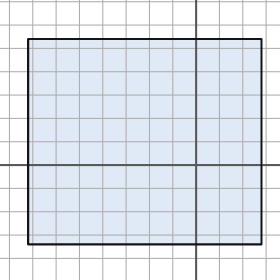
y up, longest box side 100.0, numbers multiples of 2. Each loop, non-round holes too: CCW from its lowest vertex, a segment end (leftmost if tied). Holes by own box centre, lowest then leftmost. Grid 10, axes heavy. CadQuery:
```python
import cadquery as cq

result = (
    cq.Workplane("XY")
    .moveTo(-72.0, -34.0)
    .lineTo(28.0, -34.0)
    .lineTo(28.0, 54.0)
    .lineTo(-72.0, 54.0)
    .close()
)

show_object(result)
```